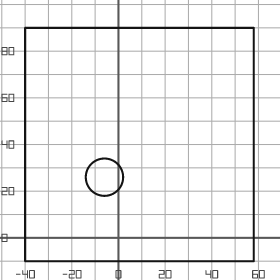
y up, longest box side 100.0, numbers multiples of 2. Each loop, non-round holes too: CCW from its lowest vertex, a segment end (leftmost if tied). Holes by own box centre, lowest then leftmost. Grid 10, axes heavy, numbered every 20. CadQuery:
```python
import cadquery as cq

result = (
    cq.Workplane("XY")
    .moveTo(-40.0, -10.0)
    .lineTo(58.0, -10.0)
    .lineTo(58.0, 90.0)
    .lineTo(-40.0, 90.0)
    .close()
    .moveTo(-6.0, 26.0)
    .circle(8.0)
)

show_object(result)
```